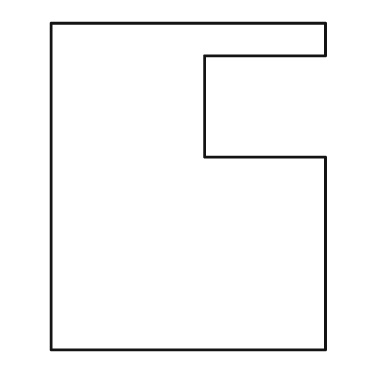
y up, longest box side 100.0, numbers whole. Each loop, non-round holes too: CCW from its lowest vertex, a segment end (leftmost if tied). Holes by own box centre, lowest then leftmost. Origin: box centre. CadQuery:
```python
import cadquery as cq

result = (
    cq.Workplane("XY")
    .moveTo(-42.0, -50.0)
    .lineTo(42.0, -50.0)
    .lineTo(42.0, 9.0)
    .lineTo(5.0, 9.0)
    .lineTo(5.0, 40.0)
    .lineTo(42.0, 40.0)
    .lineTo(42.0, 50.0)
    .lineTo(-42.0, 50.0)
    .close()
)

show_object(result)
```